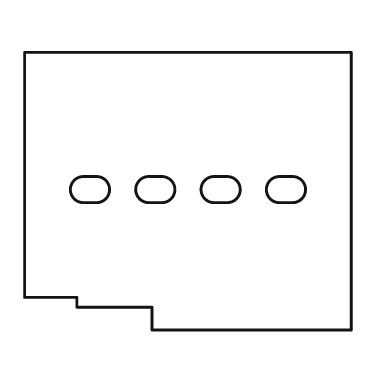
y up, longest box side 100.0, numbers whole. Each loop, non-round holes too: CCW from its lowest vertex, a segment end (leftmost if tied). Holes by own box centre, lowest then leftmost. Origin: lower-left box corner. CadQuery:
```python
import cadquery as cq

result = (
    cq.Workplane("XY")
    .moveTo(39.0, 0.0)
    .lineTo(100.0, 0.0)
    .lineTo(100.0, 85.0)
    .lineTo(0.0, 85.0)
    .lineTo(0.0, 10.0)
    .lineTo(16.0, 10.0)
    .lineTo(16.0, 7.0)
    .lineTo(39.0, 7.0)
    .close()
    .moveTo(18.0, 39.0)
    .lineTo(22.0, 39.0)
    .threePointArc((26.0, 43.0), (22.0, 47.0))
    .lineTo(18.0, 47.0)
    .threePointArc((14.0, 43.0), (18.0, 39.0))
    .close()
    .moveTo(38.0, 39.0)
    .lineTo(42.0, 39.0)
    .threePointArc((46.0, 43.0), (42.0, 47.0))
    .lineTo(38.0, 47.0)
    .threePointArc((34.0, 43.0), (38.0, 39.0))
    .close()
    .moveTo(58.0, 39.0)
    .lineTo(62.0, 39.0)
    .threePointArc((66.0, 43.0), (62.0, 47.0))
    .lineTo(58.0, 47.0)
    .threePointArc((54.0, 43.0), (58.0, 39.0))
    .close()
    .moveTo(78.0, 39.0)
    .lineTo(82.0, 39.0)
    .threePointArc((86.0, 43.0), (82.0, 47.0))
    .lineTo(78.0, 47.0)
    .threePointArc((74.0, 43.0), (78.0, 39.0))
    .close()
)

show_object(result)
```